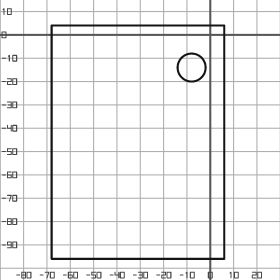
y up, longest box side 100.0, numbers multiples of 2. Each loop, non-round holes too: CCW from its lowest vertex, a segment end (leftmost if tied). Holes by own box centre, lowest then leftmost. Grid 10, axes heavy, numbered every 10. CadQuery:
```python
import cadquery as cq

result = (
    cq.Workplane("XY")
    .moveTo(-68.0, -96.0)
    .lineTo(6.0, -96.0)
    .lineTo(6.0, 4.0)
    .lineTo(-68.0, 4.0)
    .close()
    .moveTo(-8.0, -14.0)
    .circle(6.0)
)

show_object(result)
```